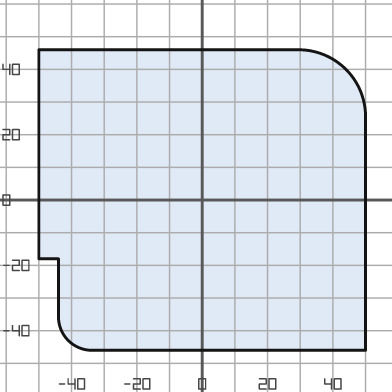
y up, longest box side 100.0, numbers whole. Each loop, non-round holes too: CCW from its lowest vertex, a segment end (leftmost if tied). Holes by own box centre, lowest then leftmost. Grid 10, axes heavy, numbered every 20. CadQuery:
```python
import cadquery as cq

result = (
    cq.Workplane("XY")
    .moveTo(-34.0, -46.0)
    .lineTo(50.0, -46.0)
    .lineTo(50.0, 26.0)
    .threePointArc((44.0, 40.0), (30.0, 46.0))
    .lineTo(-50.0, 46.0)
    .lineTo(-50.0, -18.0)
    .lineTo(-44.0, -18.0)
    .lineTo(-44.0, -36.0)
    .threePointArc((-41.0, -43.0), (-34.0, -46.0))
    .close()
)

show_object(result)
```